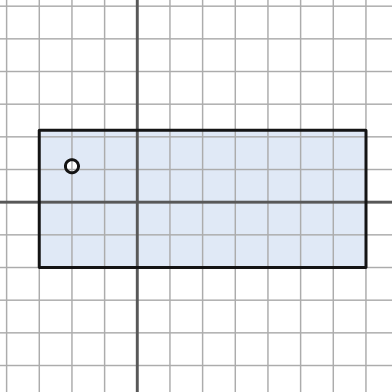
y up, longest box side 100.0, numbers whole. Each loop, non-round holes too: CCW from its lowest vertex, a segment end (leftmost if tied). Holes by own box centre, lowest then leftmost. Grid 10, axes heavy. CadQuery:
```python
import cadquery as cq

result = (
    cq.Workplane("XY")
    .moveTo(-30.0, -20.0)
    .lineTo(70.0, -20.0)
    .lineTo(70.0, 22.0)
    .lineTo(-30.0, 22.0)
    .close()
    .moveTo(-20.0, 11.0)
    .circle(2.0)
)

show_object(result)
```